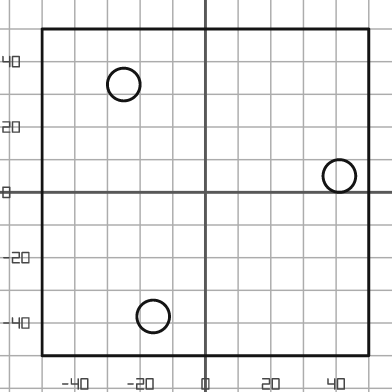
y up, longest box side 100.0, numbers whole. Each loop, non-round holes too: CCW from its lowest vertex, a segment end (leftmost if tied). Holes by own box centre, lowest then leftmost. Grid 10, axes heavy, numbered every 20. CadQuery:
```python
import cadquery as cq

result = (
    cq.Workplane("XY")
    .moveTo(-50.0, -50.0)
    .lineTo(50.0, -50.0)
    .lineTo(50.0, 50.0)
    .lineTo(-50.0, 50.0)
    .close()
    .moveTo(-16.0, -38.0)
    .circle(5.0)
    .moveTo(41.0, 5.0)
    .circle(5.0)
    .moveTo(-25.0, 33.0)
    .circle(5.0)
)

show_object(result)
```